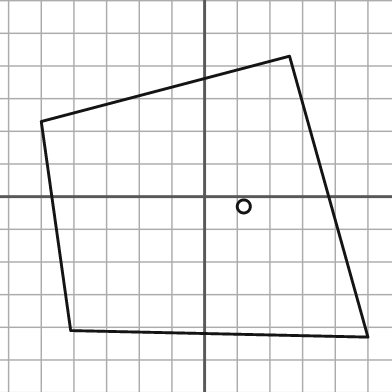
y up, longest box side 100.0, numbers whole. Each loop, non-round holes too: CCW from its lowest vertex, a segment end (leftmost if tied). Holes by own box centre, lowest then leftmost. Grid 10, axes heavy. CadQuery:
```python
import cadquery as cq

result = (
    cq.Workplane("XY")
    .moveTo(50.0, -43.0)
    .lineTo(26.0, 43.0)
    .lineTo(-50.0, 23.0)
    .lineTo(-41.0, -41.0)
    .close()
    .moveTo(12.0, -3.0)
    .circle(2.0)
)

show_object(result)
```